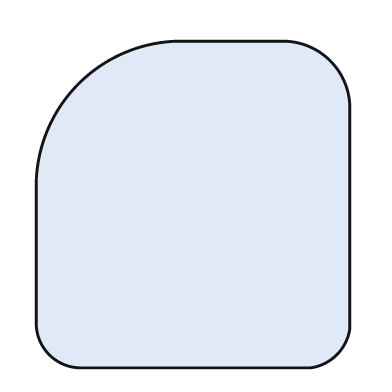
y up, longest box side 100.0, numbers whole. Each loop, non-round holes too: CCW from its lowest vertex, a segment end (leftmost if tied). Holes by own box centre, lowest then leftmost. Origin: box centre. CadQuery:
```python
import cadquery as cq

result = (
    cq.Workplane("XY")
    .moveTo(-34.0, -50.0)
    .lineTo(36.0, -50.0)
    .threePointArc((44.0, -46.0), (48.0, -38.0))
    .lineTo(48.0, 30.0)
    .threePointArc((42.0, 44.0), (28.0, 50.0))
    .lineTo(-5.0, 50.0)
    .threePointArc((-35.0, 37.0), (-48.0, 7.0))
    .lineTo(-48.0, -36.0)
    .threePointArc((-44.0, -46.0), (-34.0, -50.0))
    .close()
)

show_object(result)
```